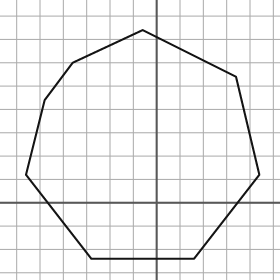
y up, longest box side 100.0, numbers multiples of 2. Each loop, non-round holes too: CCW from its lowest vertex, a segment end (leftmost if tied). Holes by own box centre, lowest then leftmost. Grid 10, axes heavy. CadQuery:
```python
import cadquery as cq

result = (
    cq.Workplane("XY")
    .moveTo(-28.0, -24.0)
    .lineTo(16.0, -24.0)
    .lineTo(44.0, 12.0)
    .lineTo(34.0, 54.0)
    .lineTo(-6.0, 74.0)
    .lineTo(-36.0, 60.0)
    .lineTo(-48.0, 44.0)
    .lineTo(-56.0, 12.0)
    .close()
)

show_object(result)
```